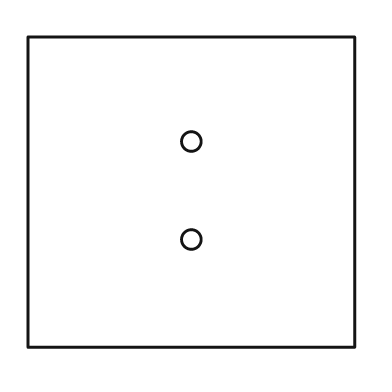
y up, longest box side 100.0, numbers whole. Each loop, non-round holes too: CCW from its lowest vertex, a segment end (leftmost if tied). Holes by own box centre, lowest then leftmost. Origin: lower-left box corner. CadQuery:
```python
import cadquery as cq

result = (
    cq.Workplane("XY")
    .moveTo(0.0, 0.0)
    .lineTo(100.0, 0.0)
    .lineTo(100.0, 95.0)
    .lineTo(0.0, 95.0)
    .close()
    .moveTo(50.0, 33.0)
    .circle(3.0)
    .moveTo(50.0, 63.0)
    .circle(3.0)
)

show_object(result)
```